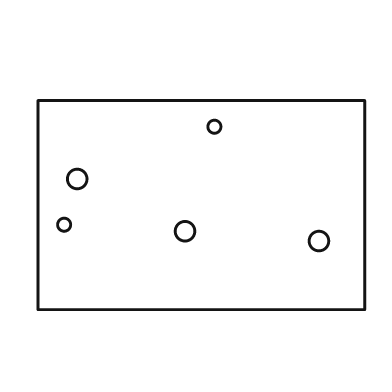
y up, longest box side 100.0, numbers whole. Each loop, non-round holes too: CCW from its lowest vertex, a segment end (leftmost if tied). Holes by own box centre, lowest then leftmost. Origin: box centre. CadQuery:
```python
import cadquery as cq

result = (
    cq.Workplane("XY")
    .moveTo(-50.0, -32.0)
    .lineTo(50.0, -32.0)
    .lineTo(50.0, 32.0)
    .lineTo(-50.0, 32.0)
    .close()
    .moveTo(36.0, -11.0)
    .circle(3.0)
    .moveTo(-5.0, -8.0)
    .circle(3.0)
    .moveTo(-42.0, -6.0)
    .circle(2.0)
    .moveTo(-38.0, 8.0)
    .circle(3.0)
    .moveTo(4.0, 24.0)
    .circle(2.0)
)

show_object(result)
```